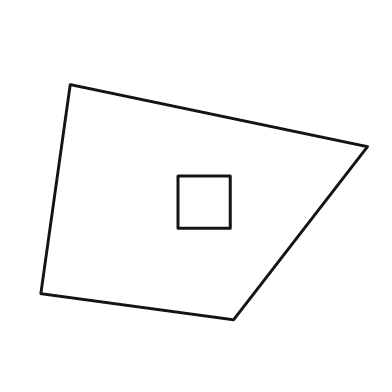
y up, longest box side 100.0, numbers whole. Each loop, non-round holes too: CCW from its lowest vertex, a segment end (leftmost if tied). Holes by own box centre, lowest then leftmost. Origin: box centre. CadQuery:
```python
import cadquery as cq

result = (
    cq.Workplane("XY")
    .moveTo(9.0, -36.0)
    .lineTo(50.0, 17.0)
    .lineTo(-41.0, 36.0)
    .lineTo(-50.0, -28.0)
    .close()
    .moveTo(-8.0, -8.0)
    .lineTo(8.0, -8.0)
    .lineTo(8.0, 8.0)
    .lineTo(-8.0, 8.0)
    .close()
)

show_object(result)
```